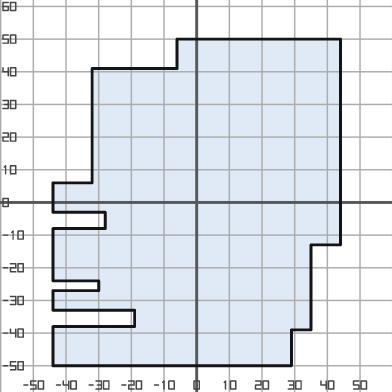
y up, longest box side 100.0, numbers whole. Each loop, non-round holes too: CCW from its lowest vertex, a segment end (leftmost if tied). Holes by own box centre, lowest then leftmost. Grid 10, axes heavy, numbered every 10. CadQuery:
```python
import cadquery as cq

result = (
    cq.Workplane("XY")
    .moveTo(-44.0, -50.0)
    .lineTo(29.0, -50.0)
    .lineTo(29.0, -39.0)
    .lineTo(35.0, -39.0)
    .lineTo(35.0, -13.0)
    .lineTo(44.0, -13.0)
    .lineTo(44.0, 50.0)
    .lineTo(-6.0, 50.0)
    .lineTo(-6.0, 41.0)
    .lineTo(-32.0, 41.0)
    .lineTo(-32.0, 6.0)
    .lineTo(-44.0, 6.0)
    .lineTo(-44.0, -3.0)
    .lineTo(-28.0, -3.0)
    .lineTo(-28.0, -8.0)
    .lineTo(-44.0, -8.0)
    .lineTo(-44.0, -24.0)
    .lineTo(-30.0, -24.0)
    .lineTo(-30.0, -27.0)
    .lineTo(-44.0, -27.0)
    .lineTo(-44.0, -33.0)
    .lineTo(-19.0, -33.0)
    .lineTo(-19.0, -38.0)
    .lineTo(-44.0, -38.0)
    .close()
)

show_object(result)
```